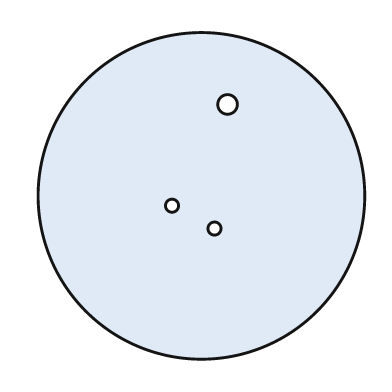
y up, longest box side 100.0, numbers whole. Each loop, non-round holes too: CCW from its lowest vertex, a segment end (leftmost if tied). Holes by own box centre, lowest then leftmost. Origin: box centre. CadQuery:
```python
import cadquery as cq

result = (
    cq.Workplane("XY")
    .moveTo(0.0, 0.0)
    .circle(50.0)
    .moveTo(4.0, -10.0)
    .circle(2.0)
    .moveTo(-9.0, -3.0)
    .circle(2.0)
    .moveTo(8.0, 28.0)
    .circle(3.0)
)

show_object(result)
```